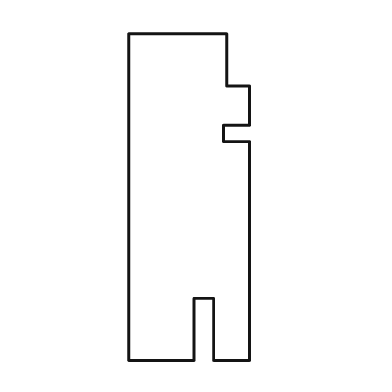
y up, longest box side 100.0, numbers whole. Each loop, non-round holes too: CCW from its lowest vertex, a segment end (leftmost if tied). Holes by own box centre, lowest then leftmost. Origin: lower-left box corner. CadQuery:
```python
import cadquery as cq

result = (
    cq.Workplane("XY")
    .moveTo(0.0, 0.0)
    .lineTo(20.0, 0.0)
    .lineTo(20.0, 19.0)
    .lineTo(26.0, 19.0)
    .lineTo(26.0, 0.0)
    .lineTo(37.0, 0.0)
    .lineTo(37.0, 67.0)
    .lineTo(29.0, 67.0)
    .lineTo(29.0, 72.0)
    .lineTo(37.0, 72.0)
    .lineTo(37.0, 84.0)
    .lineTo(30.0, 84.0)
    .lineTo(30.0, 100.0)
    .lineTo(0.0, 100.0)
    .close()
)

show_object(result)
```